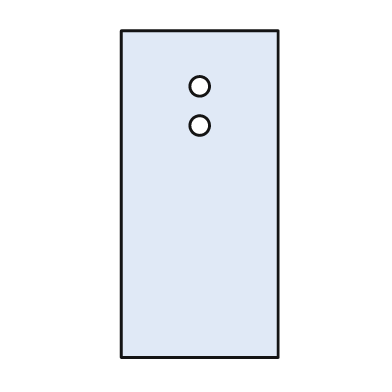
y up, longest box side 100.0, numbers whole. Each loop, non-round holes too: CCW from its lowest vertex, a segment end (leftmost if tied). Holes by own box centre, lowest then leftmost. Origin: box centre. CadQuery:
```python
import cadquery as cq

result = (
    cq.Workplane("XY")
    .moveTo(-24.0, -50.0)
    .lineTo(24.0, -50.0)
    .lineTo(24.0, 50.0)
    .lineTo(-24.0, 50.0)
    .close()
    .moveTo(0.0, 21.0)
    .circle(3.0)
    .moveTo(0.0, 33.0)
    .circle(3.0)
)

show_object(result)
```